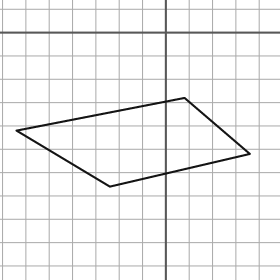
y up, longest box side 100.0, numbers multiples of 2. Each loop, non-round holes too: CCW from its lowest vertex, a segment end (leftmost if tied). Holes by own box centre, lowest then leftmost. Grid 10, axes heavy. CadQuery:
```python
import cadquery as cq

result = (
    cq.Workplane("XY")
    .moveTo(-24.0, -66.0)
    .lineTo(36.0, -52.0)
    .lineTo(8.0, -28.0)
    .lineTo(-64.0, -42.0)
    .close()
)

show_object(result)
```